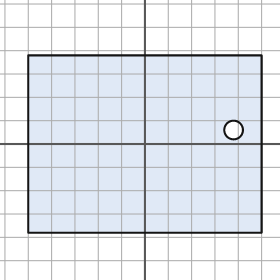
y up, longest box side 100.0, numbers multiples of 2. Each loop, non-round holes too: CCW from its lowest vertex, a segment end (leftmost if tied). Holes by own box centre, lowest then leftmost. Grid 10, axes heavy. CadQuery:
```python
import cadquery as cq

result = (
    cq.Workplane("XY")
    .moveTo(-50.0, -38.0)
    .lineTo(50.0, -38.0)
    .lineTo(50.0, 38.0)
    .lineTo(-50.0, 38.0)
    .close()
    .moveTo(38.0, 6.0)
    .circle(4.0)
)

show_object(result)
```